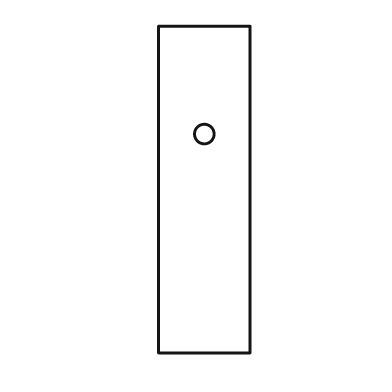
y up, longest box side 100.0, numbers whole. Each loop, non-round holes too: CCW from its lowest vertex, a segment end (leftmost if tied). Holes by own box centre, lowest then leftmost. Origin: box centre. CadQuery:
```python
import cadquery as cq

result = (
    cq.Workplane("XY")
    .moveTo(-14.0, -50.0)
    .lineTo(14.0, -50.0)
    .lineTo(14.0, 50.0)
    .lineTo(-14.0, 50.0)
    .close()
    .moveTo(0.0, 17.0)
    .circle(3.0)
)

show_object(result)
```